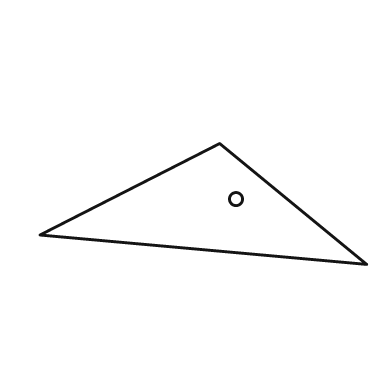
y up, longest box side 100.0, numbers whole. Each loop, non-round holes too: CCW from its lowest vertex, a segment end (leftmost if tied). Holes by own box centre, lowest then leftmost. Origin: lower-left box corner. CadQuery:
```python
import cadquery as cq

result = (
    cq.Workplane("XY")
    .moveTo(100.0, 0.0)
    .lineTo(55.0, 37.0)
    .lineTo(0.0, 9.0)
    .close()
    .moveTo(60.0, 20.0)
    .circle(2.0)
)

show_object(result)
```